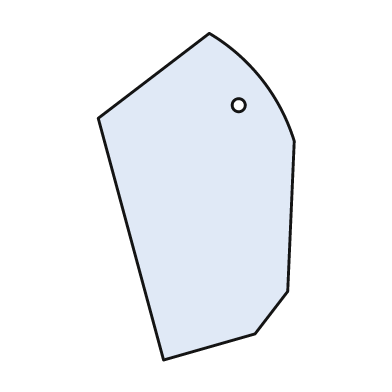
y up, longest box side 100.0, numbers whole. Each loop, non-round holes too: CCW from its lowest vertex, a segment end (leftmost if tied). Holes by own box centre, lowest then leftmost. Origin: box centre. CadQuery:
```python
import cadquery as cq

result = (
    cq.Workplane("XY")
    .moveTo(-10.0, -50.0)
    .lineTo(18.0, -42.0)
    .lineTo(28.0, -29.0)
    .lineTo(30.0, 17.0)
    .threePointArc((20.0, 36.0), (4.0, 50.0))
    .lineTo(-30.0, 24.0)
    .close()
    .moveTo(13.0, 28.0)
    .circle(2.0)
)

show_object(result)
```